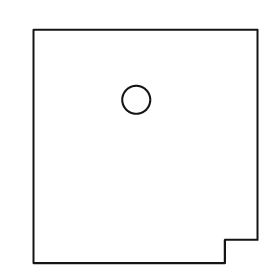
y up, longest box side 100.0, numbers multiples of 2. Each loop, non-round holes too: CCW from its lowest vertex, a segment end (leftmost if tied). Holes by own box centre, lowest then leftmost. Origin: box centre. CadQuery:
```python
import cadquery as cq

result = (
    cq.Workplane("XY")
    .moveTo(-48.0, -50.0)
    .lineTo(34.0, -50.0)
    .lineTo(34.0, -40.0)
    .lineTo(48.0, -40.0)
    .lineTo(48.0, 50.0)
    .lineTo(-48.0, 50.0)
    .close()
    .moveTo(-4.0, 20.0)
    .circle(6.0)
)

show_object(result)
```